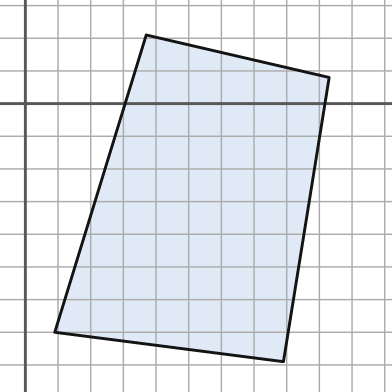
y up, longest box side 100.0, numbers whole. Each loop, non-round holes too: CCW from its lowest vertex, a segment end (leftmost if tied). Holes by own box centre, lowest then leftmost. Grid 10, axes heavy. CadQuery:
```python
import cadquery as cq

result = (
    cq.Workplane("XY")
    .moveTo(79.0, -79.0)
    .lineTo(93.0, 8.0)
    .lineTo(37.0, 21.0)
    .lineTo(9.0, -70.0)
    .close()
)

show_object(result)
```